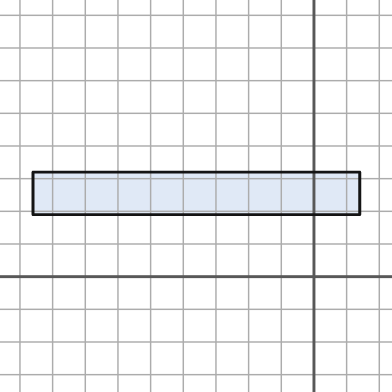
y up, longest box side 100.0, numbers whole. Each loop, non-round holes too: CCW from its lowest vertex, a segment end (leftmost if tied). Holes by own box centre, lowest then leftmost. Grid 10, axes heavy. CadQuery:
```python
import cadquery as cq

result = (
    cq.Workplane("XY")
    .moveTo(-86.0, 19.0)
    .lineTo(14.0, 19.0)
    .lineTo(14.0, 32.0)
    .lineTo(-86.0, 32.0)
    .close()
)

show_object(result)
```